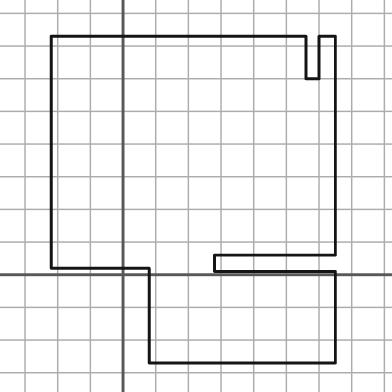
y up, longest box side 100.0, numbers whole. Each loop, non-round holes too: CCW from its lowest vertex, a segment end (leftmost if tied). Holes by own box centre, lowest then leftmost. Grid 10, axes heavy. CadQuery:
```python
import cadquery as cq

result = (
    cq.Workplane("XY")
    .moveTo(8.0, -27.0)
    .lineTo(65.0, -27.0)
    .lineTo(65.0, 1.0)
    .lineTo(28.0, 1.0)
    .lineTo(28.0, 6.0)
    .lineTo(65.0, 6.0)
    .lineTo(65.0, 73.0)
    .lineTo(60.0, 73.0)
    .lineTo(60.0, 60.0)
    .lineTo(56.0, 60.0)
    .lineTo(56.0, 73.0)
    .lineTo(-22.0, 73.0)
    .lineTo(-22.0, 2.0)
    .lineTo(8.0, 2.0)
    .close()
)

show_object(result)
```